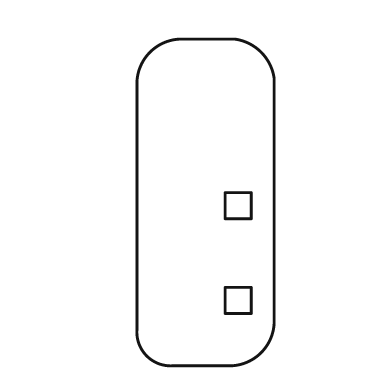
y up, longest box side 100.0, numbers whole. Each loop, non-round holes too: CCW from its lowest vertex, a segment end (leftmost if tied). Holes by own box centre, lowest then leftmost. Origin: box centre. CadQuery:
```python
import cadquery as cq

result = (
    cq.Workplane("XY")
    .moveTo(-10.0, -50.0)
    .lineTo(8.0, -50.0)
    .threePointArc((17.0, -46.0), (21.0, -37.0))
    .lineTo(21.0, 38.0)
    .threePointArc((17.0, 46.0), (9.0, 50.0))
    .lineTo(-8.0, 50.0)
    .threePointArc((-17.0, 46.0), (-21.0, 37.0))
    .lineTo(-21.0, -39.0)
    .threePointArc((-18.0, -47.0), (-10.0, -50.0))
    .close()
    .moveTo(6.0, -34.0)
    .lineTo(14.0, -34.0)
    .lineTo(14.0, -26.0)
    .lineTo(6.0, -26.0)
    .close()
    .moveTo(6.0, -5.0)
    .lineTo(14.0, -5.0)
    .lineTo(14.0, 3.0)
    .lineTo(6.0, 3.0)
    .close()
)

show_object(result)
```